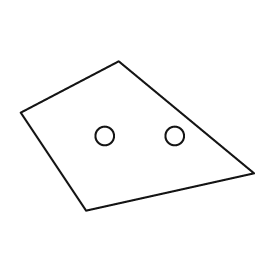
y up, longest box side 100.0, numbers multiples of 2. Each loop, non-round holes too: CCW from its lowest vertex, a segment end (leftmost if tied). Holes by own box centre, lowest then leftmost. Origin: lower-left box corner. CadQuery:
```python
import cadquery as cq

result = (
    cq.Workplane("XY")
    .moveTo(28.0, 0.0)
    .lineTo(100.0, 16.0)
    .lineTo(42.0, 64.0)
    .lineTo(0.0, 42.0)
    .close()
    .moveTo(36.0, 32.0)
    .circle(4.0)
    .moveTo(66.0, 32.0)
    .circle(4.0)
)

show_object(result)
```